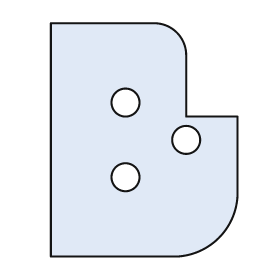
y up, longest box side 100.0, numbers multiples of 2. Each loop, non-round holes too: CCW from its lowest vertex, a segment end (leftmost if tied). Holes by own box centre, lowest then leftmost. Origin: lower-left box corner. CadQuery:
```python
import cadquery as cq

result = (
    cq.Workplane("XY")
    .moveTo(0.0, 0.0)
    .lineTo(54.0, 0.0)
    .threePointArc((72.0, 8.0), (80.0, 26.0))
    .lineTo(80.0, 60.0)
    .lineTo(58.0, 60.0)
    .lineTo(58.0, 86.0)
    .threePointArc((54.0, 96.0), (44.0, 100.0))
    .lineTo(0.0, 100.0)
    .close()
    .moveTo(32.0, 34.0)
    .circle(6.0)
    .moveTo(58.0, 50.0)
    .circle(6.0)
    .moveTo(32.0, 66.0)
    .circle(6.0)
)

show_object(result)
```